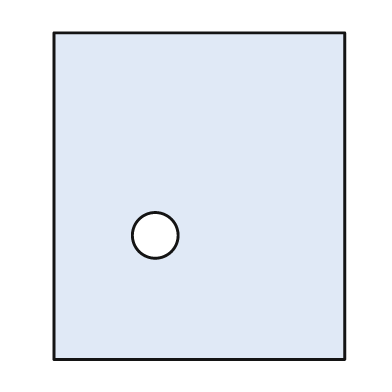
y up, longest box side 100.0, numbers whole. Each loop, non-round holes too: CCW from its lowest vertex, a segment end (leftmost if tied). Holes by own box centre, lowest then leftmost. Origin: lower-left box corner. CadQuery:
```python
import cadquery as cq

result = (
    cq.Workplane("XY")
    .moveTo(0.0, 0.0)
    .lineTo(89.0, 0.0)
    .lineTo(89.0, 100.0)
    .lineTo(0.0, 100.0)
    .close()
    .moveTo(31.0, 38.0)
    .circle(7.0)
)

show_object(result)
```